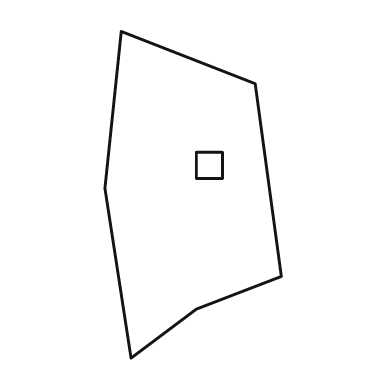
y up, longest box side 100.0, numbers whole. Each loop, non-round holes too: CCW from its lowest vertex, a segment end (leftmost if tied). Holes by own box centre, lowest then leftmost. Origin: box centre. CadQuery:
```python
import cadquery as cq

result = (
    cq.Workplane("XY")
    .moveTo(-19.0, -50.0)
    .lineTo(1.0, -35.0)
    .lineTo(27.0, -25.0)
    .lineTo(19.0, 34.0)
    .lineTo(-22.0, 50.0)
    .lineTo(-27.0, 2.0)
    .close()
    .moveTo(1.0, 5.0)
    .lineTo(9.0, 5.0)
    .lineTo(9.0, 13.0)
    .lineTo(1.0, 13.0)
    .close()
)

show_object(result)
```